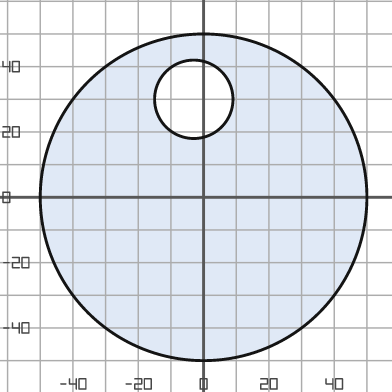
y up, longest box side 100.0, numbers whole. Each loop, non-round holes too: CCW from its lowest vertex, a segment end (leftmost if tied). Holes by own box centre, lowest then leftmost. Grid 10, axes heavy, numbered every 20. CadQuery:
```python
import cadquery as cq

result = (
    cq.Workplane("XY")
    .moveTo(0.0, 0.0)
    .circle(50.0)
    .moveTo(-3.0, 30.0)
    .circle(12.0)
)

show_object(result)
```